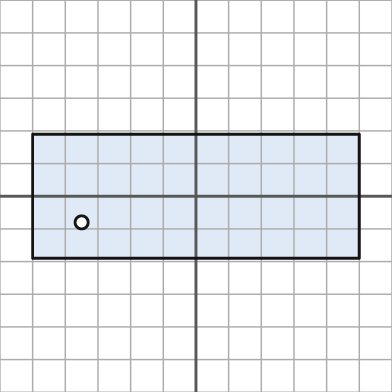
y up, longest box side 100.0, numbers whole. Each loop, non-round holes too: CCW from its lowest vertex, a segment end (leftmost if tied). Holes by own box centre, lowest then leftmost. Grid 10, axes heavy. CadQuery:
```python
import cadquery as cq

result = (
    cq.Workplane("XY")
    .moveTo(-50.0, -19.0)
    .lineTo(50.0, -19.0)
    .lineTo(50.0, 19.0)
    .lineTo(-50.0, 19.0)
    .close()
    .moveTo(-35.0, -8.0)
    .circle(2.0)
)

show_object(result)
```